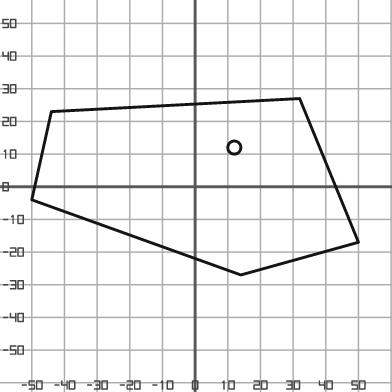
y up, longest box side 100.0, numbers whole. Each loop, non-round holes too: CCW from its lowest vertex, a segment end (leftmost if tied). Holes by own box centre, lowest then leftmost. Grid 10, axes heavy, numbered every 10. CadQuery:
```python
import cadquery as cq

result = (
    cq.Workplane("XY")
    .moveTo(14.0, -27.0)
    .lineTo(50.0, -17.0)
    .lineTo(32.0, 27.0)
    .lineTo(-44.0, 23.0)
    .lineTo(-50.0, -4.0)
    .close()
    .moveTo(12.0, 12.0)
    .circle(2.0)
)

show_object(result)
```